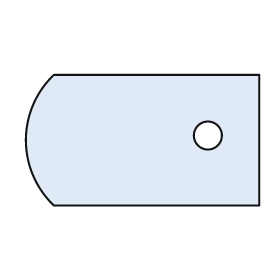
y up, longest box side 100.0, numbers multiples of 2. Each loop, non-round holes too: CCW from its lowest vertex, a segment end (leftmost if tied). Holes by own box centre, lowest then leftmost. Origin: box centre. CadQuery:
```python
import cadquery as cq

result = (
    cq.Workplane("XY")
    .moveTo(-38.0, -28.0)
    .lineTo(50.0, -28.0)
    .lineTo(50.0, 28.0)
    .lineTo(-38.0, 28.0)
    .threePointArc((-50.0, 0.0), (-38.0, -28.0))
    .close()
    .moveTo(28.0, 2.0)
    .circle(6.0)
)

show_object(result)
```